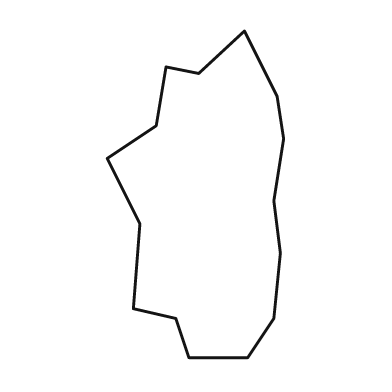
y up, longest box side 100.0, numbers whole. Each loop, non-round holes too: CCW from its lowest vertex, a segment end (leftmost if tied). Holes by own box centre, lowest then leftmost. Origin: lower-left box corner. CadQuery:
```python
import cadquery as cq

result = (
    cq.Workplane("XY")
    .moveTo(25.0, 0.0)
    .lineTo(43.0, 0.0)
    .lineTo(51.0, 12.0)
    .lineTo(53.0, 32.0)
    .lineTo(51.0, 48.0)
    .lineTo(54.0, 67.0)
    .lineTo(52.0, 80.0)
    .lineTo(42.0, 100.0)
    .lineTo(28.0, 87.0)
    .lineTo(18.0, 89.0)
    .lineTo(15.0, 71.0)
    .lineTo(0.0, 61.0)
    .lineTo(10.0, 41.0)
    .lineTo(8.0, 15.0)
    .lineTo(21.0, 12.0)
    .close()
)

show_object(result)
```